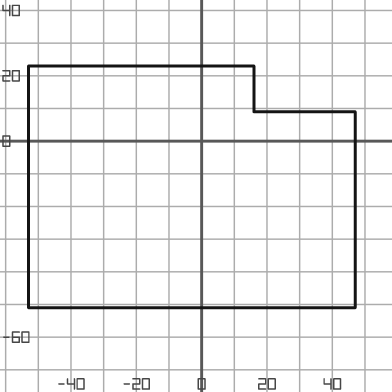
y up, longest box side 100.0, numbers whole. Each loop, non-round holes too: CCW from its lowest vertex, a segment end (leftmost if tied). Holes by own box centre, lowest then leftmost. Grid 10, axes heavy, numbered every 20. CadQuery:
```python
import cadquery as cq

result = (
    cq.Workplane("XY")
    .moveTo(-53.0, -51.0)
    .lineTo(47.0, -51.0)
    .lineTo(47.0, 9.0)
    .lineTo(16.0, 9.0)
    .lineTo(16.0, 23.0)
    .lineTo(-53.0, 23.0)
    .close()
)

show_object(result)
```